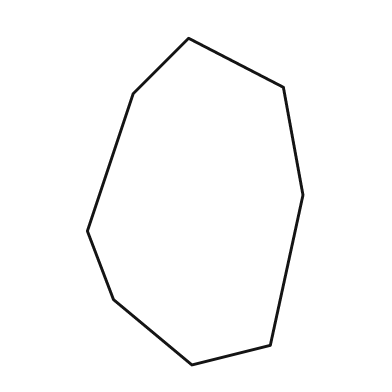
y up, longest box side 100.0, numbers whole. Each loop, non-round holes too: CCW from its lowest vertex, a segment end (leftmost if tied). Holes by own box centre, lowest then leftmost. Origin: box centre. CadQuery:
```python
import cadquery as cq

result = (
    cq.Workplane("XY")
    .moveTo(-1.0, -50.0)
    .lineTo(23.0, -44.0)
    .lineTo(33.0, 2.0)
    .lineTo(27.0, 35.0)
    .lineTo(-2.0, 50.0)
    .lineTo(-19.0, 33.0)
    .lineTo(-33.0, -9.0)
    .lineTo(-25.0, -30.0)
    .close()
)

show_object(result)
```